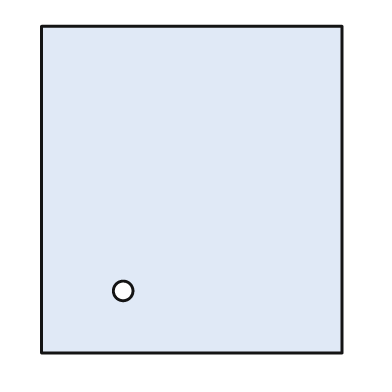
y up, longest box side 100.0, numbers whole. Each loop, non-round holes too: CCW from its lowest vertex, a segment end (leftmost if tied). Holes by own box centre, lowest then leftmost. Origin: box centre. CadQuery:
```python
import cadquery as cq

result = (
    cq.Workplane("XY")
    .moveTo(-46.0, -50.0)
    .lineTo(46.0, -50.0)
    .lineTo(46.0, 50.0)
    .lineTo(-46.0, 50.0)
    .close()
    .moveTo(-21.0, -31.0)
    .circle(3.0)
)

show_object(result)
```